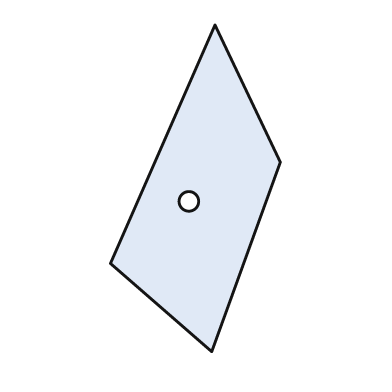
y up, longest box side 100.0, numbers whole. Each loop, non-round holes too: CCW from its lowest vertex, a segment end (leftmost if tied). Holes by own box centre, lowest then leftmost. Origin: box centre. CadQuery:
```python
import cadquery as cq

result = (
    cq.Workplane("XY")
    .moveTo(5.0, -50.0)
    .lineTo(26.0, 8.0)
    .lineTo(6.0, 50.0)
    .lineTo(-26.0, -23.0)
    .close()
    .moveTo(-2.0, -4.0)
    .circle(3.0)
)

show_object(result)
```